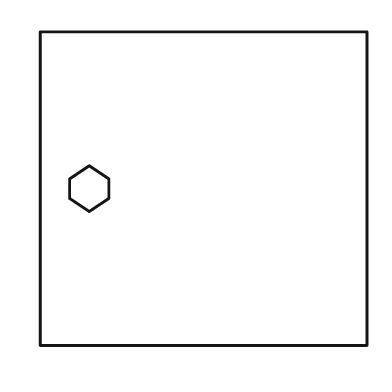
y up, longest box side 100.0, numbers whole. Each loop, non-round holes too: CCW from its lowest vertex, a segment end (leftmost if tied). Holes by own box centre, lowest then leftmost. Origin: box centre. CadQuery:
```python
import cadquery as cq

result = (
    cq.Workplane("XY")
    .moveTo(-50.0, -48.0)
    .lineTo(50.0, -48.0)
    .lineTo(50.0, 48.0)
    .lineTo(-50.0, 48.0)
    .close()
    .moveTo(-35.0, -7.0)
    .lineTo(-29.0, -3.0)
    .lineTo(-29.0, 3.0)
    .lineTo(-35.0, 7.0)
    .lineTo(-41.0, 3.0)
    .lineTo(-41.0, -3.0)
    .close()
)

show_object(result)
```